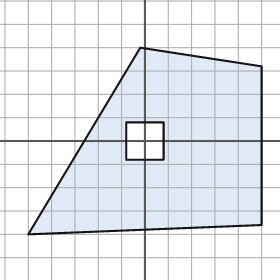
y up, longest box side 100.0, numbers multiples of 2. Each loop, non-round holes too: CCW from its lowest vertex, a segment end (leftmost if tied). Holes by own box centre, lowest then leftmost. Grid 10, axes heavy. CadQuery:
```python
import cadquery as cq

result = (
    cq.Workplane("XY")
    .moveTo(-50.0, -40.0)
    .lineTo(50.0, -36.0)
    .lineTo(50.0, 32.0)
    .lineTo(-2.0, 40.0)
    .close()
    .moveTo(-8.0, -8.0)
    .lineTo(8.0, -8.0)
    .lineTo(8.0, 8.0)
    .lineTo(-8.0, 8.0)
    .close()
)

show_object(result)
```